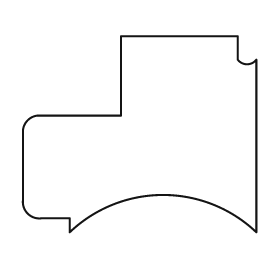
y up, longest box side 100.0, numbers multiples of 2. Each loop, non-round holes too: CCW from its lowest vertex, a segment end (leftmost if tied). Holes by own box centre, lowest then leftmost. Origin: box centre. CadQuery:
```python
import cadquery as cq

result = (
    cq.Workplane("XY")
    .moveTo(-30.0, -42.0)
    .threePointArc((10.0, -26.0), (50.0, -42.0))
    .lineTo(50.0, 32.0)
    .threePointArc((46.0, 30.0), (42.0, 32.0))
    .lineTo(42.0, 42.0)
    .lineTo(-8.0, 42.0)
    .lineTo(-8.0, 8.0)
    .lineTo(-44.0, 8.0)
    .threePointArc((-48.0, 6.0), (-50.0, 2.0))
    .lineTo(-50.0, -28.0)
    .threePointArc((-48.0, -34.0), (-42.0, -36.0))
    .lineTo(-30.0, -36.0)
    .close()
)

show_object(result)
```